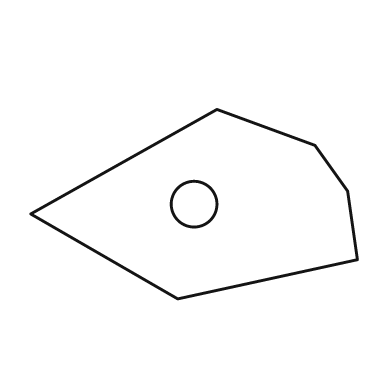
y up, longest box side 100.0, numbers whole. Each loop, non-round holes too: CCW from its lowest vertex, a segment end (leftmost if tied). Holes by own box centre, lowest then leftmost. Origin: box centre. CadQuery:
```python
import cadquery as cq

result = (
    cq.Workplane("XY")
    .moveTo(-5.0, -29.0)
    .lineTo(50.0, -17.0)
    .lineTo(47.0, 4.0)
    .lineTo(37.0, 18.0)
    .lineTo(7.0, 29.0)
    .lineTo(-50.0, -3.0)
    .close()
    .moveTo(0.0, 0.0)
    .circle(7.0)
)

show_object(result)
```